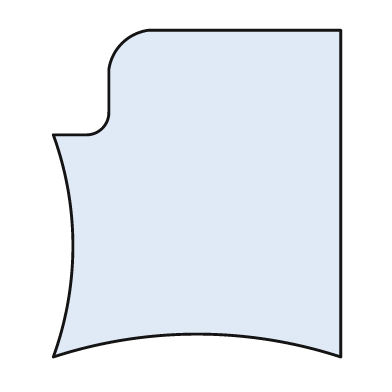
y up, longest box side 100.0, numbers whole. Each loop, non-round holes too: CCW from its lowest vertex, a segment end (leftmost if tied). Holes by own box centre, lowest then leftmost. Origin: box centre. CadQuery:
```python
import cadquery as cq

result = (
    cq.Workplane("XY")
    .moveTo(-44.0, -50.0)
    .threePointArc((0.0, -43.0), (44.0, -50.0))
    .lineTo(44.0, 50.0)
    .lineTo(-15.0, 50.0)
    .threePointArc((-23.0, 46.0), (-27.0, 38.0))
    .lineTo(-27.0, 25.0)
    .threePointArc((-29.0, 20.0), (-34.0, 18.0))
    .lineTo(-44.0, 18.0)
    .threePointArc((-38.0, -16.0), (-44.0, -50.0))
    .close()
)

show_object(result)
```